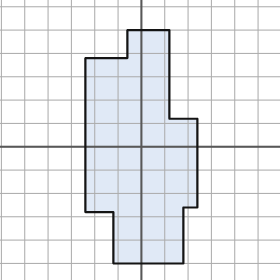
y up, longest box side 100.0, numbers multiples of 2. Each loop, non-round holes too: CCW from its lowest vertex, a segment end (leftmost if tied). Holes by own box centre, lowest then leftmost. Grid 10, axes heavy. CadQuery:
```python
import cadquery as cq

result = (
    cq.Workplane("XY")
    .moveTo(-12.0, -50.0)
    .lineTo(18.0, -50.0)
    .lineTo(18.0, -26.0)
    .lineTo(24.0, -26.0)
    .lineTo(24.0, 12.0)
    .lineTo(12.0, 12.0)
    .lineTo(12.0, 50.0)
    .lineTo(-6.0, 50.0)
    .lineTo(-6.0, 38.0)
    .lineTo(-24.0, 38.0)
    .lineTo(-24.0, -28.0)
    .lineTo(-12.0, -28.0)
    .close()
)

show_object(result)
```